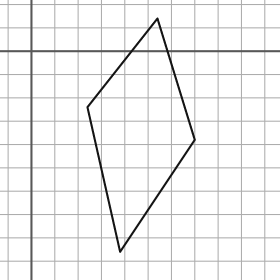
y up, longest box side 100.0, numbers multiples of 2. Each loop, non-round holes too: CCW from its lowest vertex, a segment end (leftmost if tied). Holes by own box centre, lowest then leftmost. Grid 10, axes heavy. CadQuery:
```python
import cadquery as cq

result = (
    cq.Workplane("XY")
    .moveTo(38.0, -86.0)
    .lineTo(70.0, -38.0)
    .lineTo(54.0, 14.0)
    .lineTo(24.0, -24.0)
    .close()
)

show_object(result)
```